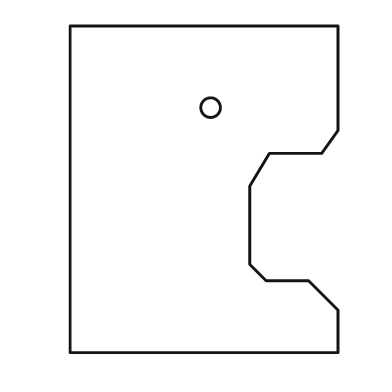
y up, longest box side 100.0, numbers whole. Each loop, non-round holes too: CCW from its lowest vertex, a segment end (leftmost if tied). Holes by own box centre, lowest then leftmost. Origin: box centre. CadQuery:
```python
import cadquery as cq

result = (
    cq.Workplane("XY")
    .moveTo(-41.0, -50.0)
    .lineTo(41.0, -50.0)
    .lineTo(41.0, -37.0)
    .lineTo(32.0, -28.0)
    .lineTo(19.0, -28.0)
    .lineTo(14.0, -23.0)
    .lineTo(14.0, 1.0)
    .lineTo(20.0, 11.0)
    .lineTo(36.0, 11.0)
    .lineTo(41.0, 18.0)
    .lineTo(41.0, 50.0)
    .lineTo(-41.0, 50.0)
    .close()
    .moveTo(2.0, 25.0)
    .circle(3.0)
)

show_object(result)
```